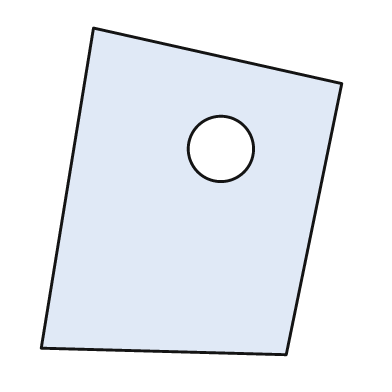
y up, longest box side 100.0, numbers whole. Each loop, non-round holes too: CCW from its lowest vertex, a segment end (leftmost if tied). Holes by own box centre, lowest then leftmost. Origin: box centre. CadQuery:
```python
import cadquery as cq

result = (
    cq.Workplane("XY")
    .moveTo(29.0, -50.0)
    .lineTo(46.0, 33.0)
    .lineTo(-30.0, 50.0)
    .lineTo(-46.0, -48.0)
    .close()
    .moveTo(9.0, 13.0)
    .circle(10.0)
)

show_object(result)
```